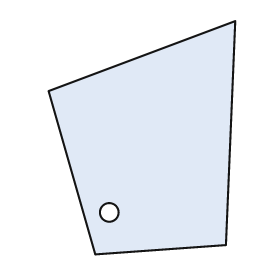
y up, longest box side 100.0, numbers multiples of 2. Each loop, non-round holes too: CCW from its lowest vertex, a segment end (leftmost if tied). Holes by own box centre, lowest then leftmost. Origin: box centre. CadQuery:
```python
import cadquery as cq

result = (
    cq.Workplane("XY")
    .moveTo(-20.0, -50.0)
    .lineTo(36.0, -46.0)
    .lineTo(40.0, 50.0)
    .lineTo(-40.0, 20.0)
    .close()
    .moveTo(-14.0, -32.0)
    .circle(4.0)
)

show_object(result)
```